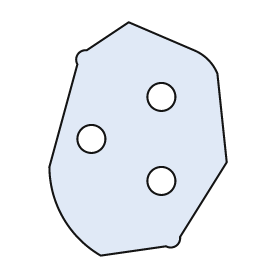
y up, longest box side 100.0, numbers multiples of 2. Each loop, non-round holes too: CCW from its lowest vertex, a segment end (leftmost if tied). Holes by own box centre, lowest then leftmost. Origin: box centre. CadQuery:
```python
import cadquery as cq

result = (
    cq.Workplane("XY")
    .moveTo(-16.0, -50.0)
    .lineTo(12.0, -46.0)
    .threePointArc((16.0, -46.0), (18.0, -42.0))
    .lineTo(38.0, -10.0)
    .lineTo(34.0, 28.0)
    .threePointArc((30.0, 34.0), (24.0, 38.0))
    .lineTo(-4.0, 50.0)
    .lineTo(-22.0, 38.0)
    .threePointArc((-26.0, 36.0), (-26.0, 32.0))
    .lineTo(-38.0, -12.0)
    .threePointArc((-32.0, -34.0), (-16.0, -50.0))
    .close()
    .moveTo(10.0, -18.0)
    .circle(6.0)
    .moveTo(-20.0, 0.0)
    .circle(6.0)
    .moveTo(10.0, 18.0)
    .circle(6.0)
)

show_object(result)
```